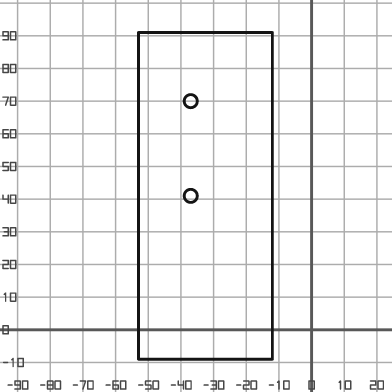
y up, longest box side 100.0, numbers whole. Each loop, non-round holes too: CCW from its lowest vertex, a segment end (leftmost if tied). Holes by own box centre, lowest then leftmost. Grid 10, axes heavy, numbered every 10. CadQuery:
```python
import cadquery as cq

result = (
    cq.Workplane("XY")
    .moveTo(-53.0, -9.0)
    .lineTo(-12.0, -9.0)
    .lineTo(-12.0, 91.0)
    .lineTo(-53.0, 91.0)
    .close()
    .moveTo(-37.0, 41.0)
    .circle(2.0)
    .moveTo(-37.0, 70.0)
    .circle(2.0)
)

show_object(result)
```